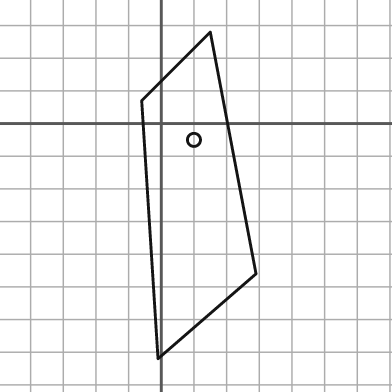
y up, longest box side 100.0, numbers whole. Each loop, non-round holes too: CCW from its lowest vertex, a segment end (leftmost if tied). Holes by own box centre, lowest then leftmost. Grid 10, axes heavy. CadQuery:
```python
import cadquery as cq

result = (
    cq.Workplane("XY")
    .moveTo(-1.0, -72.0)
    .lineTo(29.0, -46.0)
    .lineTo(15.0, 28.0)
    .lineTo(-6.0, 7.0)
    .close()
    .moveTo(10.0, -5.0)
    .circle(2.0)
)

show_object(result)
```